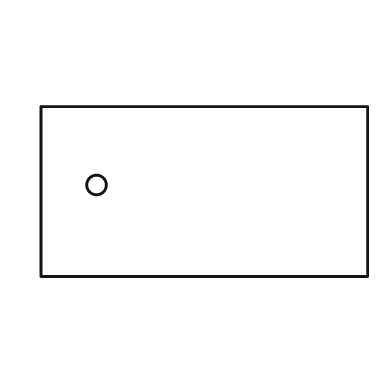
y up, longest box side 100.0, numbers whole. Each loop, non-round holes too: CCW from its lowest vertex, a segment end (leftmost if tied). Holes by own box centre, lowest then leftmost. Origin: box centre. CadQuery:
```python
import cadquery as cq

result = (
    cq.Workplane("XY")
    .moveTo(-50.0, -26.0)
    .lineTo(50.0, -26.0)
    .lineTo(50.0, 26.0)
    .lineTo(-50.0, 26.0)
    .close()
    .moveTo(-33.0, 2.0)
    .circle(3.0)
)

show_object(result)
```